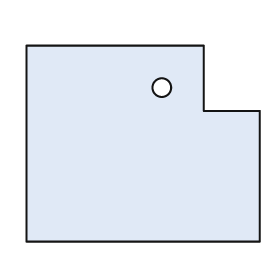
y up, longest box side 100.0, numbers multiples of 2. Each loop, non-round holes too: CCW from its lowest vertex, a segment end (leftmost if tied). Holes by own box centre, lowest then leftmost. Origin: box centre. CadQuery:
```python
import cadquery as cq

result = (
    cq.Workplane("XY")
    .moveTo(-50.0, -42.0)
    .lineTo(50.0, -42.0)
    .lineTo(50.0, 14.0)
    .lineTo(26.0, 14.0)
    .lineTo(26.0, 42.0)
    .lineTo(-50.0, 42.0)
    .close()
    .moveTo(8.0, 24.0)
    .circle(4.0)
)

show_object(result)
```